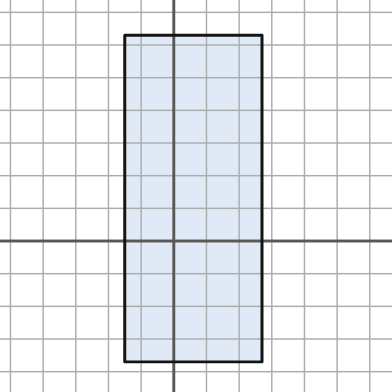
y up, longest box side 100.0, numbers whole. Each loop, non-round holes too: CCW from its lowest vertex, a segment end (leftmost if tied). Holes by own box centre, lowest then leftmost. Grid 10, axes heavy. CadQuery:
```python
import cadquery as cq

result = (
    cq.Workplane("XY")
    .moveTo(-15.0, -37.0)
    .lineTo(27.0, -37.0)
    .lineTo(27.0, 63.0)
    .lineTo(-15.0, 63.0)
    .close()
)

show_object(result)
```